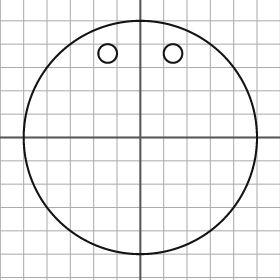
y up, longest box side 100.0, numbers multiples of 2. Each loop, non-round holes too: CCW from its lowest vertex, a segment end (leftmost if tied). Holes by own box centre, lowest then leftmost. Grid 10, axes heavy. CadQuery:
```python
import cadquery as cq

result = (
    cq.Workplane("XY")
    .moveTo(0.0, 0.0)
    .circle(50.0)
    .moveTo(-14.0, 36.0)
    .circle(4.0)
    .moveTo(14.0, 36.0)
    .circle(4.0)
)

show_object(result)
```